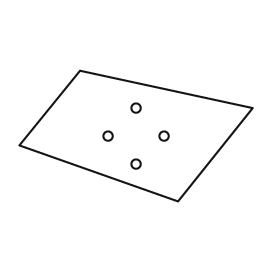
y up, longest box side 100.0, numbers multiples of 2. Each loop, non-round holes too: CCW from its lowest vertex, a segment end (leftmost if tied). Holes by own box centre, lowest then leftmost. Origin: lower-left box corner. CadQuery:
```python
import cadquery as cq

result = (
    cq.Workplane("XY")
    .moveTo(68.0, 0.0)
    .lineTo(100.0, 40.0)
    .lineTo(26.0, 56.0)
    .lineTo(0.0, 24.0)
    .close()
    .moveTo(50.0, 16.0)
    .circle(2.0)
    .moveTo(38.0, 28.0)
    .circle(2.0)
    .moveTo(62.0, 28.0)
    .circle(2.0)
    .moveTo(50.0, 40.0)
    .circle(2.0)
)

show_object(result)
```